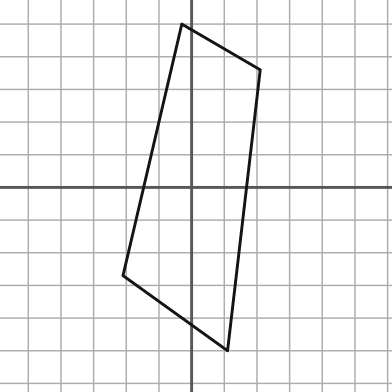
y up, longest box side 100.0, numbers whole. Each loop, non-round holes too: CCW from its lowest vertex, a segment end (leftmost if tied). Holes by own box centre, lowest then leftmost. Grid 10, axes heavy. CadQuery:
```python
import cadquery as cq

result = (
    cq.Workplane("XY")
    .moveTo(11.0, -50.0)
    .lineTo(21.0, 36.0)
    .lineTo(-3.0, 50.0)
    .lineTo(-21.0, -27.0)
    .close()
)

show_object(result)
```